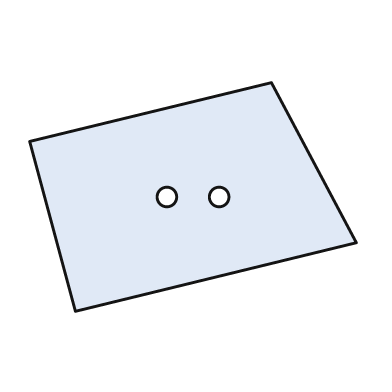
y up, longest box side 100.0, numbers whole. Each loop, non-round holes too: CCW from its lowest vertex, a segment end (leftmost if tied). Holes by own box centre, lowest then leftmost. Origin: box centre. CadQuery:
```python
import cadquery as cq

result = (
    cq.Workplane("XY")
    .moveTo(-36.0, -35.0)
    .lineTo(50.0, -14.0)
    .lineTo(24.0, 35.0)
    .lineTo(-50.0, 17.0)
    .close()
    .moveTo(-8.0, 0.0)
    .circle(3.0)
    .moveTo(8.0, 0.0)
    .circle(3.0)
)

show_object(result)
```